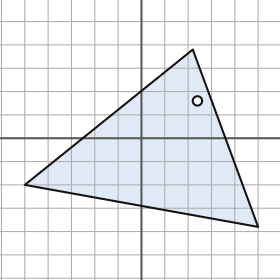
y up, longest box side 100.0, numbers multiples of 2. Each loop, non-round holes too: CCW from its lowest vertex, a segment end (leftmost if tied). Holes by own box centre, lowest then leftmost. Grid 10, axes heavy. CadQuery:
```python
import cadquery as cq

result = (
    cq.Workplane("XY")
    .moveTo(50.0, -38.0)
    .lineTo(22.0, 38.0)
    .lineTo(-50.0, -20.0)
    .close()
    .moveTo(24.0, 16.0)
    .circle(2.0)
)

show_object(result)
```